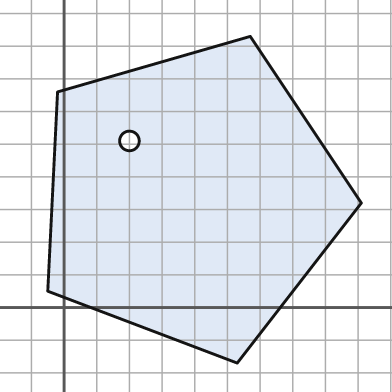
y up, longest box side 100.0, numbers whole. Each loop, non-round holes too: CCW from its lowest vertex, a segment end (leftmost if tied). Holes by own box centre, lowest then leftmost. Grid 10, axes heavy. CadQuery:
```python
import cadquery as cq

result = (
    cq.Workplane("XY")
    .moveTo(53.0, -17.0)
    .lineTo(91.0, 32.0)
    .lineTo(57.0, 83.0)
    .lineTo(-2.0, 66.0)
    .lineTo(-5.0, 5.0)
    .close()
    .moveTo(20.0, 51.0)
    .circle(3.0)
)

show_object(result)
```